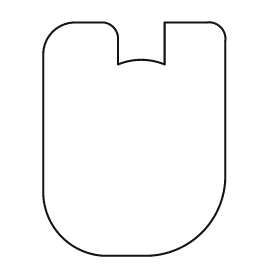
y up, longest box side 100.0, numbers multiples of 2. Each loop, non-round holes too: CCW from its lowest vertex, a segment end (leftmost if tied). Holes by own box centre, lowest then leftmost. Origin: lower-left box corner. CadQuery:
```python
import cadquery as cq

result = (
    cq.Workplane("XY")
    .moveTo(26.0, 0.0)
    .lineTo(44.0, 0.0)
    .threePointArc((68.0, 10.0), (78.0, 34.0))
    .lineTo(78.0, 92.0)
    .threePointArc((76.0, 98.0), (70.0, 100.0))
    .lineTo(52.0, 100.0)
    .lineTo(52.0, 82.0)
    .threePointArc((42.0, 84.0), (32.0, 82.0))
    .lineTo(32.0, 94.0)
    .threePointArc((30.0, 98.0), (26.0, 100.0))
    .lineTo(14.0, 100.0)
    .threePointArc((4.0, 96.0), (0.0, 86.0))
    .lineTo(0.0, 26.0)
    .threePointArc((8.0, 8.0), (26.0, 0.0))
    .close()
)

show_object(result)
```